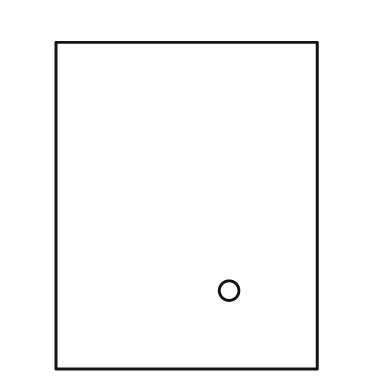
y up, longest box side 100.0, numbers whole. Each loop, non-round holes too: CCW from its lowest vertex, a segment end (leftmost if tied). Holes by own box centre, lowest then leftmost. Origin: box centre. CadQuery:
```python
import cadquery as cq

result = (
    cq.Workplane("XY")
    .moveTo(-40.0, -50.0)
    .lineTo(40.0, -50.0)
    .lineTo(40.0, 50.0)
    .lineTo(-40.0, 50.0)
    .close()
    .moveTo(13.0, -26.0)
    .circle(3.0)
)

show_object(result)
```